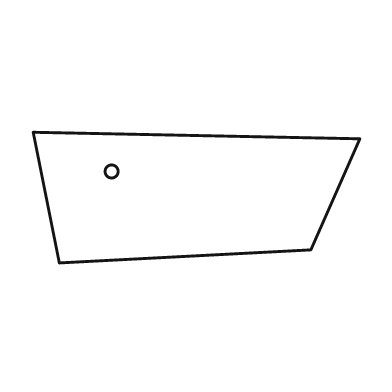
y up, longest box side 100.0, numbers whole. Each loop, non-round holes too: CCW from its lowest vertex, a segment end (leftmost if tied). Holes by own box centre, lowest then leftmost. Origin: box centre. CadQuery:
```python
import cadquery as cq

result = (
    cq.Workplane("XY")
    .moveTo(-42.0, -20.0)
    .lineTo(35.0, -16.0)
    .lineTo(50.0, 18.0)
    .lineTo(-50.0, 20.0)
    .close()
    .moveTo(-26.0, 8.0)
    .circle(2.0)
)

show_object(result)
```